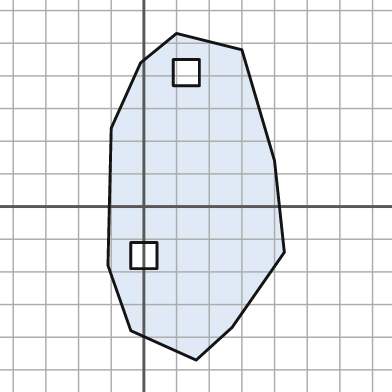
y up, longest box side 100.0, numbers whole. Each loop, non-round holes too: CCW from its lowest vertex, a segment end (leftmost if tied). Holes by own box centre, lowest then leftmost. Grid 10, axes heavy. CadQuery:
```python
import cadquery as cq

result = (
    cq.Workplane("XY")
    .moveTo(16.0, -47.0)
    .lineTo(27.0, -37.0)
    .lineTo(43.0, -14.0)
    .lineTo(40.0, 14.0)
    .lineTo(30.0, 48.0)
    .lineTo(10.0, 53.0)
    .lineTo(-1.0, 44.0)
    .lineTo(-10.0, 24.0)
    .lineTo(-11.0, -18.0)
    .lineTo(-4.0, -38.0)
    .close()
    .moveTo(-4.0, -19.0)
    .lineTo(4.0, -19.0)
    .lineTo(4.0, -11.0)
    .lineTo(-4.0, -11.0)
    .close()
    .moveTo(9.0, 37.0)
    .lineTo(17.0, 37.0)
    .lineTo(17.0, 45.0)
    .lineTo(9.0, 45.0)
    .close()
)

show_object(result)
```